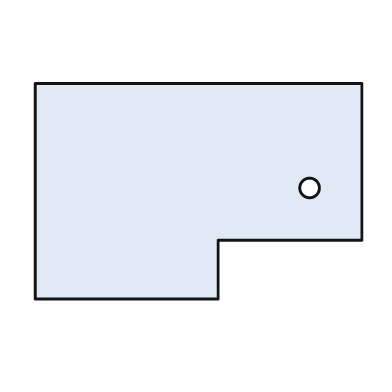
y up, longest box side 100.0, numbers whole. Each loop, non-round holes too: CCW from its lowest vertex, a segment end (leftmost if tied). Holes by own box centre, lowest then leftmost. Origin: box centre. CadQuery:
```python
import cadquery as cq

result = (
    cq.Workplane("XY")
    .moveTo(-50.0, -33.0)
    .lineTo(6.0, -33.0)
    .lineTo(6.0, -15.0)
    .lineTo(50.0, -15.0)
    .lineTo(50.0, 33.0)
    .lineTo(-50.0, 33.0)
    .close()
    .moveTo(34.0, 1.0)
    .circle(3.0)
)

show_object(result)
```